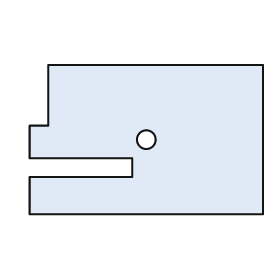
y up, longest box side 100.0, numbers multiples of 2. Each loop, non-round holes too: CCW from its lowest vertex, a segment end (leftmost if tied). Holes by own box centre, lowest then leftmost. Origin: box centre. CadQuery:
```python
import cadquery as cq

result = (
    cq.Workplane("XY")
    .moveTo(-50.0, -32.0)
    .lineTo(50.0, -32.0)
    .lineTo(50.0, 32.0)
    .lineTo(-42.0, 32.0)
    .lineTo(-42.0, 6.0)
    .lineTo(-50.0, 6.0)
    .lineTo(-50.0, -8.0)
    .lineTo(-6.0, -8.0)
    .lineTo(-6.0, -16.0)
    .lineTo(-50.0, -16.0)
    .close()
    .moveTo(0.0, 0.0)
    .circle(4.0)
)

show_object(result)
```